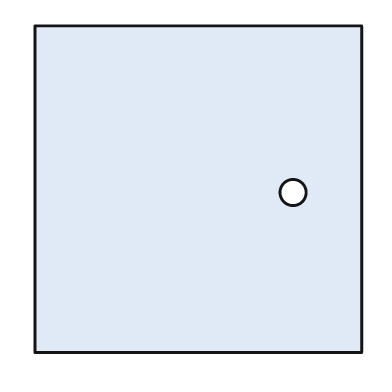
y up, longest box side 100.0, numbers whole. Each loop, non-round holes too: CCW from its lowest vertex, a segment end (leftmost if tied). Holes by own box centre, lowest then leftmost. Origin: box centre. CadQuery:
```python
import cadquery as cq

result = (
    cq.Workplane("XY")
    .moveTo(-50.0, -50.0)
    .lineTo(50.0, -50.0)
    .lineTo(50.0, 50.0)
    .lineTo(-50.0, 50.0)
    .close()
    .moveTo(29.0, -1.0)
    .circle(4.0)
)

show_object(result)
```